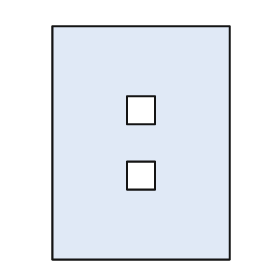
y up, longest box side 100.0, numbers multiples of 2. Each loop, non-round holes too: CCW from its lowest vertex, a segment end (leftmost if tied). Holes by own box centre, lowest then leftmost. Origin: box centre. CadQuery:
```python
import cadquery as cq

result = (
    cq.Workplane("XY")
    .moveTo(-38.0, -50.0)
    .lineTo(38.0, -50.0)
    .lineTo(38.0, 50.0)
    .lineTo(-38.0, 50.0)
    .close()
    .moveTo(-6.0, -20.0)
    .lineTo(6.0, -20.0)
    .lineTo(6.0, -8.0)
    .lineTo(-6.0, -8.0)
    .close()
    .moveTo(-6.0, 8.0)
    .lineTo(6.0, 8.0)
    .lineTo(6.0, 20.0)
    .lineTo(-6.0, 20.0)
    .close()
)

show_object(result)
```